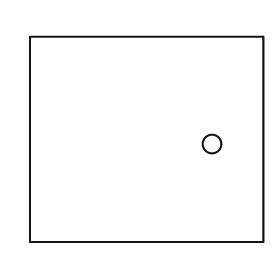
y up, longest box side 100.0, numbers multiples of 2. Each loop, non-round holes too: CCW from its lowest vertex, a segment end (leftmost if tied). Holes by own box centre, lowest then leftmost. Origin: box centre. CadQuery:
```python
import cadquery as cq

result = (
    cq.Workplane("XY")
    .moveTo(-50.0, -44.0)
    .lineTo(50.0, -44.0)
    .lineTo(50.0, 44.0)
    .lineTo(-50.0, 44.0)
    .close()
    .moveTo(28.0, -2.0)
    .circle(4.0)
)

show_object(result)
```